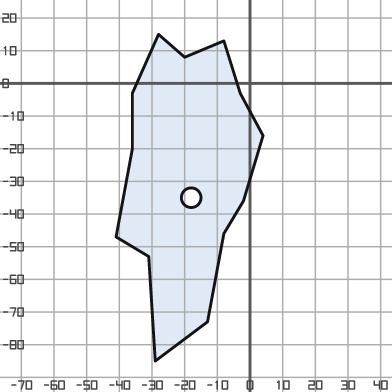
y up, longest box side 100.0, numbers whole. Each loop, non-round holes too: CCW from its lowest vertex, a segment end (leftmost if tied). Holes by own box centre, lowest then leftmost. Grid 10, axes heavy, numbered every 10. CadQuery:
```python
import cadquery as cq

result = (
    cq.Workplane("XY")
    .moveTo(-29.0, -85.0)
    .lineTo(-13.0, -73.0)
    .lineTo(-8.0, -46.0)
    .lineTo(-2.0, -36.0)
    .lineTo(4.0, -16.0)
    .lineTo(-3.0, -3.0)
    .lineTo(-8.0, 13.0)
    .lineTo(-20.0, 8.0)
    .lineTo(-28.0, 15.0)
    .lineTo(-36.0, -3.0)
    .lineTo(-36.0, -20.0)
    .lineTo(-41.0, -47.0)
    .lineTo(-31.0, -53.0)
    .close()
    .moveTo(-18.0, -35.0)
    .circle(3.0)
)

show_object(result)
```